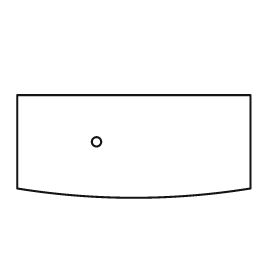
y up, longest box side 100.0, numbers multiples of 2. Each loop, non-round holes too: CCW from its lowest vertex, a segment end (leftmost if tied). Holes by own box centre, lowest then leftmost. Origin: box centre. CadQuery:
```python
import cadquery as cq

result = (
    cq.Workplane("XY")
    .moveTo(-50.0, -18.0)
    .threePointArc((0.0, -22.0), (50.0, -18.0))
    .lineTo(50.0, 22.0)
    .lineTo(-50.0, 22.0)
    .close()
    .moveTo(-16.0, 2.0)
    .circle(2.0)
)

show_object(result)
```